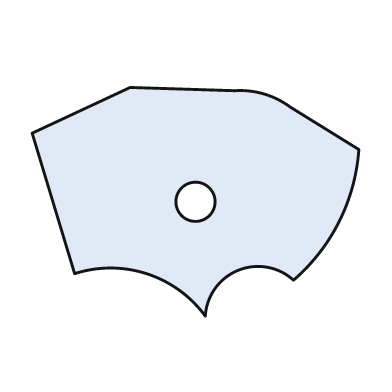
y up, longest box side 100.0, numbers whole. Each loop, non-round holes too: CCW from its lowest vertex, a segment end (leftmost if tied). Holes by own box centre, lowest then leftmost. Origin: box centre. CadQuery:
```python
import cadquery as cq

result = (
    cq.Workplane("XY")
    .moveTo(3.0, -35.0)
    .threePointArc((13.0, -21.0), (30.0, -24.0))
    .threePointArc((44.0, -6.0), (50.0, 16.0))
    .lineTo(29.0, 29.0)
    .threePointArc((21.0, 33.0), (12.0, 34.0))
    .lineTo(-20.0, 35.0)
    .lineTo(-50.0, 21.0)
    .lineTo(-37.0, -22.0)
    .threePointArc((-15.0, -22.0), (3.0, -35.0))
    .close()
    .moveTo(0.0, 0.0)
    .circle(6.0)
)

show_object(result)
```